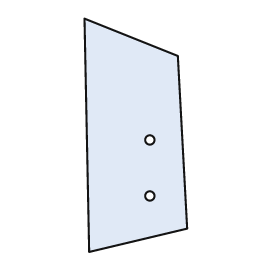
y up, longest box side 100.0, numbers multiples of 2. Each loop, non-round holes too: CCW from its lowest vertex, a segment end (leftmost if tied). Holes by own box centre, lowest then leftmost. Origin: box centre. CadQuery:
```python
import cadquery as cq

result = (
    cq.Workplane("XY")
    .moveTo(-20.0, -50.0)
    .lineTo(22.0, -40.0)
    .lineTo(18.0, 34.0)
    .lineTo(-22.0, 50.0)
    .close()
    .moveTo(6.0, -26.0)
    .circle(2.0)
    .moveTo(6.0, -2.0)
    .circle(2.0)
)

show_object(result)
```